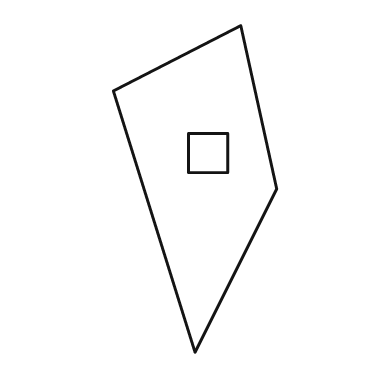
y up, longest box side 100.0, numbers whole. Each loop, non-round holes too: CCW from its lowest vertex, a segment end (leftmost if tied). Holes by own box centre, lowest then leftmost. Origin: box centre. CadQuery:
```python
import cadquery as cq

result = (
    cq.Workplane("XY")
    .moveTo(0.0, -50.0)
    .lineTo(25.0, 0.0)
    .lineTo(14.0, 50.0)
    .lineTo(-25.0, 30.0)
    .close()
    .moveTo(-2.0, 5.0)
    .lineTo(10.0, 5.0)
    .lineTo(10.0, 17.0)
    .lineTo(-2.0, 17.0)
    .close()
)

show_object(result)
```